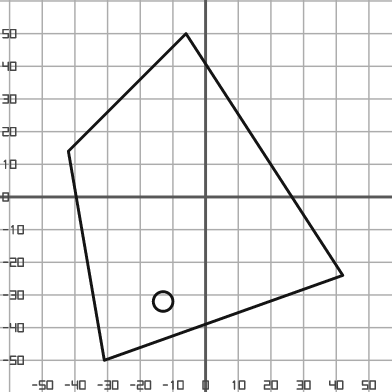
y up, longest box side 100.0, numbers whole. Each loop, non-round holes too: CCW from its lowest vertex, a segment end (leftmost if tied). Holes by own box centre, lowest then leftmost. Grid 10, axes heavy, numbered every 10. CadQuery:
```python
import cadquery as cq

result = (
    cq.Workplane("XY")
    .moveTo(-31.0, -50.0)
    .lineTo(42.0, -24.0)
    .lineTo(-6.0, 50.0)
    .lineTo(-42.0, 14.0)
    .close()
    .moveTo(-13.0, -32.0)
    .circle(3.0)
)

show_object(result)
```